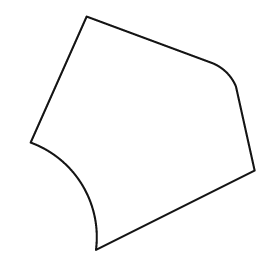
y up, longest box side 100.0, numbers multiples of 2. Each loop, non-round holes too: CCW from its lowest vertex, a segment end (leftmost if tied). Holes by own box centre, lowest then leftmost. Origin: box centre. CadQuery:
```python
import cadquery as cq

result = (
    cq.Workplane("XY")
    .moveTo(-20.0, -50.0)
    .lineTo(48.0, -16.0)
    .lineTo(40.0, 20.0)
    .threePointArc((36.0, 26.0), (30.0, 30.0))
    .lineTo(-24.0, 50.0)
    .lineTo(-48.0, -4.0)
    .threePointArc((-26.0, -22.0), (-20.0, -50.0))
    .close()
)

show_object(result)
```